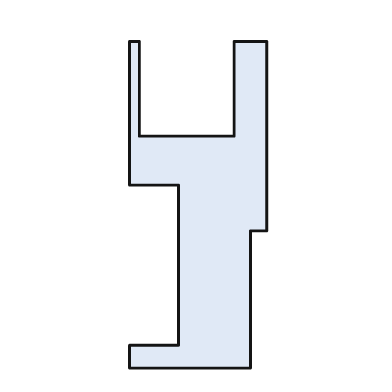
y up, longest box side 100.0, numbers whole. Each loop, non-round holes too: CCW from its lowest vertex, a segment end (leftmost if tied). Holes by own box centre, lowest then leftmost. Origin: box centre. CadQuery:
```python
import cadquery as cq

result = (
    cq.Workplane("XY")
    .moveTo(-21.0, -50.0)
    .lineTo(16.0, -50.0)
    .lineTo(16.0, -8.0)
    .lineTo(21.0, -8.0)
    .lineTo(21.0, 50.0)
    .lineTo(11.0, 50.0)
    .lineTo(11.0, 21.0)
    .lineTo(-18.0, 21.0)
    .lineTo(-18.0, 50.0)
    .lineTo(-21.0, 50.0)
    .lineTo(-21.0, 6.0)
    .lineTo(-6.0, 6.0)
    .lineTo(-6.0, -43.0)
    .lineTo(-21.0, -43.0)
    .close()
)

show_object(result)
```